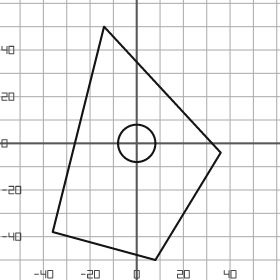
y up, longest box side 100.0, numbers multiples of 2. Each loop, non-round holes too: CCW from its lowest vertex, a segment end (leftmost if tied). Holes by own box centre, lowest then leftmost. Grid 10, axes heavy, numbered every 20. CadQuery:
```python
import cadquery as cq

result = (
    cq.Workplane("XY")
    .moveTo(8.0, -50.0)
    .lineTo(36.0, -4.0)
    .lineTo(-14.0, 50.0)
    .lineTo(-36.0, -38.0)
    .close()
    .moveTo(0.0, 0.0)
    .circle(8.0)
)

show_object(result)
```